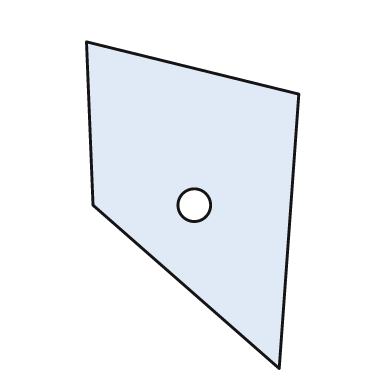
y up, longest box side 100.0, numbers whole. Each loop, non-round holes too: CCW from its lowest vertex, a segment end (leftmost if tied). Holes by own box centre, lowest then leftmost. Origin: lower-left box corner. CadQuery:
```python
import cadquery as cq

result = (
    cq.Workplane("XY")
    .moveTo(59.0, 0.0)
    .lineTo(65.0, 84.0)
    .lineTo(0.0, 100.0)
    .lineTo(2.0, 50.0)
    .close()
    .moveTo(33.0, 50.0)
    .circle(5.0)
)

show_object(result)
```